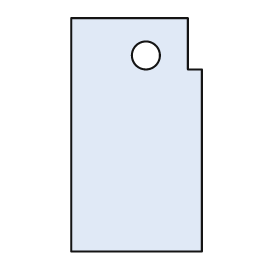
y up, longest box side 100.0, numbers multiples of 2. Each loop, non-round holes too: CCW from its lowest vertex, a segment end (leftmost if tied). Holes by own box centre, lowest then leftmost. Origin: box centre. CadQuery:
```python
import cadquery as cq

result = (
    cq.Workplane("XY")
    .moveTo(-28.0, -50.0)
    .lineTo(28.0, -50.0)
    .lineTo(28.0, 28.0)
    .lineTo(22.0, 28.0)
    .lineTo(22.0, 50.0)
    .lineTo(-28.0, 50.0)
    .close()
    .moveTo(4.0, 34.0)
    .circle(6.0)
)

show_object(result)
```